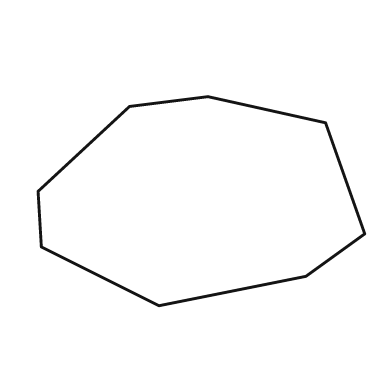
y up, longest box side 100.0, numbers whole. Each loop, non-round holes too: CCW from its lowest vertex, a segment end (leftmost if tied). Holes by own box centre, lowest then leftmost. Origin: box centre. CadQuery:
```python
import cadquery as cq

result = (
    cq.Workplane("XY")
    .moveTo(-13.0, -32.0)
    .lineTo(32.0, -23.0)
    .lineTo(50.0, -10.0)
    .lineTo(38.0, 24.0)
    .lineTo(2.0, 32.0)
    .lineTo(-22.0, 29.0)
    .lineTo(-50.0, 3.0)
    .lineTo(-49.0, -14.0)
    .close()
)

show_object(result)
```